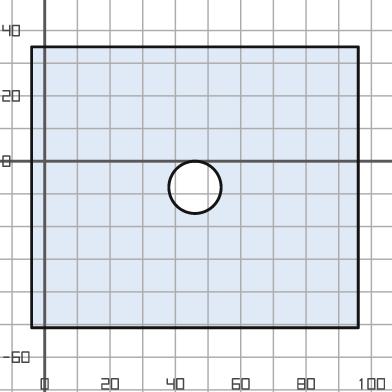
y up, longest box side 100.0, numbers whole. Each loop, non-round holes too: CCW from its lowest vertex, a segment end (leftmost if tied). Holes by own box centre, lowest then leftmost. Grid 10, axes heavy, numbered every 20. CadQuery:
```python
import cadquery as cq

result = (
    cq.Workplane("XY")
    .moveTo(-4.0, -51.0)
    .lineTo(96.0, -51.0)
    .lineTo(96.0, 35.0)
    .lineTo(-4.0, 35.0)
    .close()
    .moveTo(46.0, -8.0)
    .circle(8.0)
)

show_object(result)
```